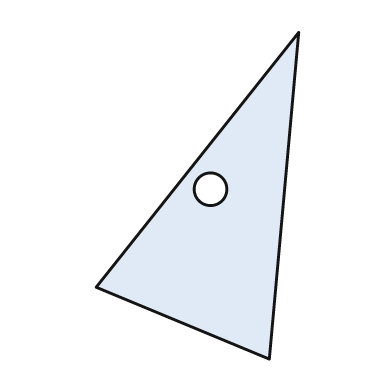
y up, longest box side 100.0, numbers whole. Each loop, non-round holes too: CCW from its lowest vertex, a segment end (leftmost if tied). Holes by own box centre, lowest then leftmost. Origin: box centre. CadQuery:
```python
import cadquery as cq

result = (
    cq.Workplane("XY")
    .moveTo(22.0, -50.0)
    .lineTo(31.0, 50.0)
    .lineTo(-31.0, -28.0)
    .close()
    .moveTo(4.0, 2.0)
    .circle(5.0)
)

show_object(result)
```